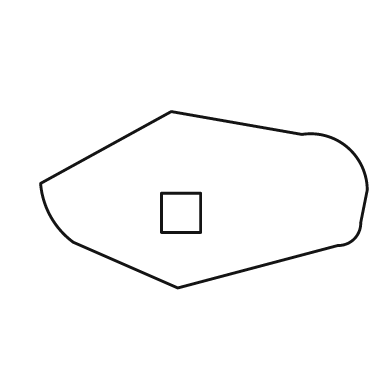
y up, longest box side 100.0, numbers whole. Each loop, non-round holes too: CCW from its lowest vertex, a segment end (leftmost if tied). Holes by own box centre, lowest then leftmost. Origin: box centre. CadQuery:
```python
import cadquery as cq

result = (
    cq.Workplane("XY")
    .moveTo(-8.0, -27.0)
    .lineTo(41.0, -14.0)
    .threePointArc((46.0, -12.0), (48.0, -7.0))
    .lineTo(50.0, 3.0)
    .threePointArc((44.0, 16.0), (30.0, 20.0))
    .lineTo(-10.0, 27.0)
    .lineTo(-50.0, 5.0)
    .threePointArc((-47.0, -5.0), (-40.0, -13.0))
    .close()
    .moveTo(-13.0, -10.0)
    .lineTo(-1.0, -10.0)
    .lineTo(-1.0, 2.0)
    .lineTo(-13.0, 2.0)
    .close()
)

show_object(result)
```